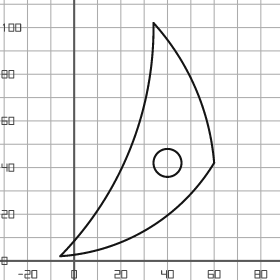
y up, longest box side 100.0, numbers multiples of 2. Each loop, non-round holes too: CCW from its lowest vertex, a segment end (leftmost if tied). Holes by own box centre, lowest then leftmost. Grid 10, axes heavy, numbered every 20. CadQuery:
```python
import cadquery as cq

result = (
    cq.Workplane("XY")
    .moveTo(-6.0, 2.0)
    .threePointArc((32.0, 14.0), (60.0, 42.0))
    .threePointArc((52.0, 74.0), (34.0, 102.0))
    .threePointArc((24.0, 48.0), (-6.0, 2.0))
    .close()
    .moveTo(40.0, 42.0)
    .circle(6.0)
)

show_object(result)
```